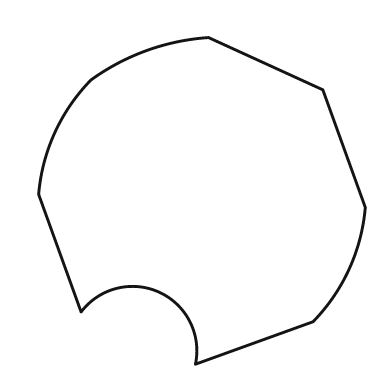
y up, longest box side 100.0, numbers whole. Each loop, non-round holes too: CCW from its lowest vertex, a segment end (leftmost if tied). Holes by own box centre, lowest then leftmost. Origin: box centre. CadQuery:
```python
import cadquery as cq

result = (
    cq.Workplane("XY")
    .moveTo(-2.0, -50.0)
    .lineTo(34.0, -37.0)
    .threePointArc((45.0, -21.0), (50.0, -2.0))
    .lineTo(37.0, 34.0)
    .lineTo(2.0, 50.0)
    .threePointArc((-17.0, 46.0), (-34.0, 37.0))
    .threePointArc((-45.0, 21.0), (-50.0, 2.0))
    .lineTo(-37.0, -34.0)
    .threePointArc((-13.0, -28.0), (-2.0, -50.0))
    .close()
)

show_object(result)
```